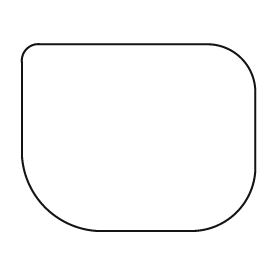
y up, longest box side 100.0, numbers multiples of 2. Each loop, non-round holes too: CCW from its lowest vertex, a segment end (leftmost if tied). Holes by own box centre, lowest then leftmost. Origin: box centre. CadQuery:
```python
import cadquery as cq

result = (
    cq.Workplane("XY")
    .moveTo(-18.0, -40.0)
    .lineTo(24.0, -40.0)
    .threePointArc((42.0, -32.0), (50.0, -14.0))
    .lineTo(50.0, 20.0)
    .threePointArc((44.0, 34.0), (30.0, 40.0))
    .lineTo(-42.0, 40.0)
    .threePointArc((-48.0, 38.0), (-50.0, 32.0))
    .lineTo(-50.0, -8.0)
    .threePointArc((-40.0, -30.0), (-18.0, -40.0))
    .close()
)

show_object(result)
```